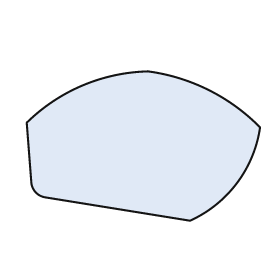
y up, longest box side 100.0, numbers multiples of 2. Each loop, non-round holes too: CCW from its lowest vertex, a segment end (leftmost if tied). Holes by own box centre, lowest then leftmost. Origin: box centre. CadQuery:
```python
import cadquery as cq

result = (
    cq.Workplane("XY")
    .moveTo(20.0, -32.0)
    .threePointArc((40.0, -16.0), (50.0, 8.0))
    .threePointArc((28.0, 24.0), (2.0, 32.0))
    .threePointArc((-26.0, 26.0), (-50.0, 10.0))
    .lineTo(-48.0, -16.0)
    .threePointArc((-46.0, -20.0), (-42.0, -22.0))
    .close()
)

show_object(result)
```